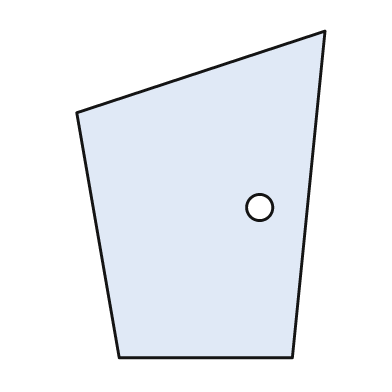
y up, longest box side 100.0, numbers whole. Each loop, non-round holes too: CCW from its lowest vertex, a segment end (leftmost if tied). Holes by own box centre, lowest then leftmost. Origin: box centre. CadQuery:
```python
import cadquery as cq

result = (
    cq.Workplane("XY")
    .moveTo(-25.0, -50.0)
    .lineTo(28.0, -50.0)
    .lineTo(38.0, 50.0)
    .lineTo(-38.0, 25.0)
    .close()
    .moveTo(18.0, -4.0)
    .circle(4.0)
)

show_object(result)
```